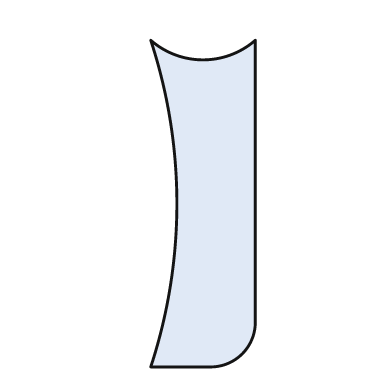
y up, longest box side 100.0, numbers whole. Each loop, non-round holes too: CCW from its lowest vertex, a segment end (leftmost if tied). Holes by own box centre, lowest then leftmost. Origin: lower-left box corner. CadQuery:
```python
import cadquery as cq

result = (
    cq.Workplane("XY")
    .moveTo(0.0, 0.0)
    .lineTo(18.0, 0.0)
    .threePointArc((28.0, 4.0), (32.0, 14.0))
    .lineTo(32.0, 100.0)
    .threePointArc((16.0, 94.0), (0.0, 100.0))
    .threePointArc((8.0, 50.0), (0.0, 0.0))
    .close()
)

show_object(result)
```